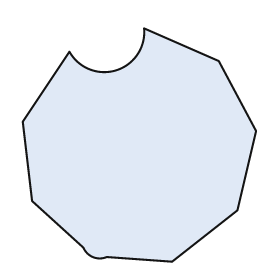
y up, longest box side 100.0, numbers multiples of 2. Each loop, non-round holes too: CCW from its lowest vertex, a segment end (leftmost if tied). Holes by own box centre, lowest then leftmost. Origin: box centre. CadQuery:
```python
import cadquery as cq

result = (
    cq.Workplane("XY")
    .moveTo(14.0, -50.0)
    .lineTo(42.0, -28.0)
    .lineTo(50.0, 6.0)
    .lineTo(34.0, 36.0)
    .lineTo(2.0, 50.0)
    .threePointArc((-10.0, 32.0), (-30.0, 40.0))
    .lineTo(-50.0, 10.0)
    .lineTo(-46.0, -24.0)
    .lineTo(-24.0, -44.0)
    .threePointArc((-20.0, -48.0), (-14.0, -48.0))
    .close()
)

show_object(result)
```